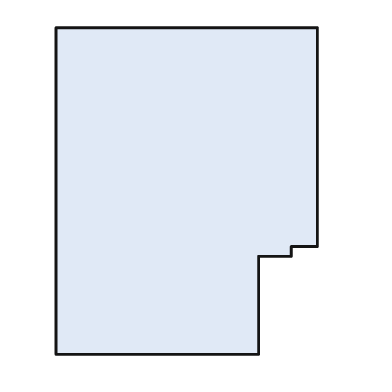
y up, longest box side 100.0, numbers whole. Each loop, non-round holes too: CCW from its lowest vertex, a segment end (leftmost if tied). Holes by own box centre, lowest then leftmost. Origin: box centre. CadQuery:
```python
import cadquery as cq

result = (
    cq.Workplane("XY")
    .moveTo(-40.0, -50.0)
    .lineTo(22.0, -50.0)
    .lineTo(22.0, -20.0)
    .lineTo(32.0, -20.0)
    .lineTo(32.0, -17.0)
    .lineTo(40.0, -17.0)
    .lineTo(40.0, 50.0)
    .lineTo(-40.0, 50.0)
    .close()
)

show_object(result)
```